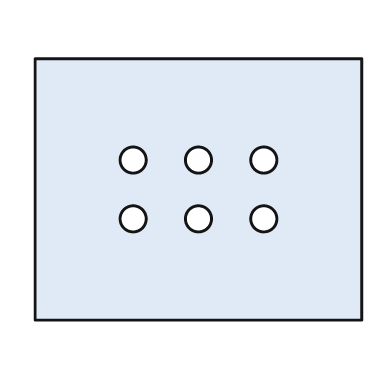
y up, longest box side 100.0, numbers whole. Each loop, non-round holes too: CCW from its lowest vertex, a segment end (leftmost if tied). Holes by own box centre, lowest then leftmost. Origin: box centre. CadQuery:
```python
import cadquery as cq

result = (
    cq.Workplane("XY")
    .moveTo(-50.0, -40.0)
    .lineTo(50.0, -40.0)
    .lineTo(50.0, 40.0)
    .lineTo(-50.0, 40.0)
    .close()
    .moveTo(-20.0, -9.0)
    .circle(4.0)
    .moveTo(0.0, -9.0)
    .circle(4.0)
    .moveTo(20.0, -9.0)
    .circle(4.0)
    .moveTo(-20.0, 9.0)
    .circle(4.0)
    .moveTo(0.0, 9.0)
    .circle(4.0)
    .moveTo(20.0, 9.0)
    .circle(4.0)
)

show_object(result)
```